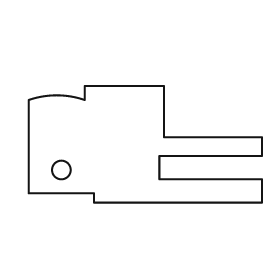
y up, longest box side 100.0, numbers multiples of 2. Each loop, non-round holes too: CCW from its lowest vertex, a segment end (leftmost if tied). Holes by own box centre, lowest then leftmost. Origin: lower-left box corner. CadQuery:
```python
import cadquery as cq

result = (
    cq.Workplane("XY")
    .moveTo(28.0, 0.0)
    .lineTo(100.0, 0.0)
    .lineTo(100.0, 10.0)
    .lineTo(56.0, 10.0)
    .lineTo(56.0, 20.0)
    .lineTo(100.0, 20.0)
    .lineTo(100.0, 28.0)
    .lineTo(58.0, 28.0)
    .lineTo(58.0, 50.0)
    .lineTo(24.0, 50.0)
    .lineTo(24.0, 44.0)
    .threePointArc((12.0, 46.0), (0.0, 44.0))
    .lineTo(0.0, 4.0)
    .lineTo(28.0, 4.0)
    .close()
    .moveTo(14.0, 14.0)
    .circle(4.0)
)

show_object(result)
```